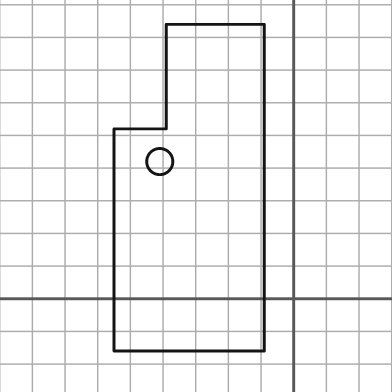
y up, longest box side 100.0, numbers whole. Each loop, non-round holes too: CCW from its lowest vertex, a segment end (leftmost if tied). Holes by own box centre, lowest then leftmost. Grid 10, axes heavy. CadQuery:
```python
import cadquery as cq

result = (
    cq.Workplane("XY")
    .moveTo(-55.0, -16.0)
    .lineTo(-9.0, -16.0)
    .lineTo(-9.0, 84.0)
    .lineTo(-39.0, 84.0)
    .lineTo(-39.0, 52.0)
    .lineTo(-55.0, 52.0)
    .close()
    .moveTo(-41.0, 42.0)
    .circle(4.0)
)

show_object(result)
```